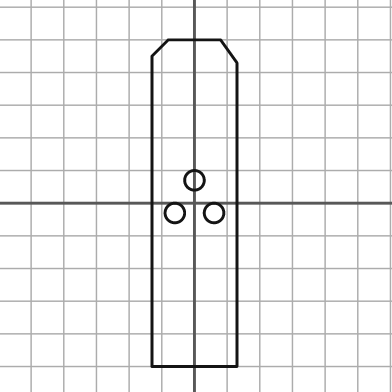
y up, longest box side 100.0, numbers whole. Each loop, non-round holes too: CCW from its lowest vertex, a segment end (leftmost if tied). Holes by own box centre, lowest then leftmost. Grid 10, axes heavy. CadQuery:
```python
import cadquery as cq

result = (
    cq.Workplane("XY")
    .moveTo(-13.0, -50.0)
    .lineTo(13.0, -50.0)
    .lineTo(13.0, 43.0)
    .lineTo(8.0, 50.0)
    .lineTo(-8.0, 50.0)
    .lineTo(-13.0, 45.0)
    .close()
    .moveTo(-6.0, -3.0)
    .circle(3.0)
    .moveTo(6.0, -3.0)
    .circle(3.0)
    .moveTo(0.0, 7.0)
    .circle(3.0)
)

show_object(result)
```